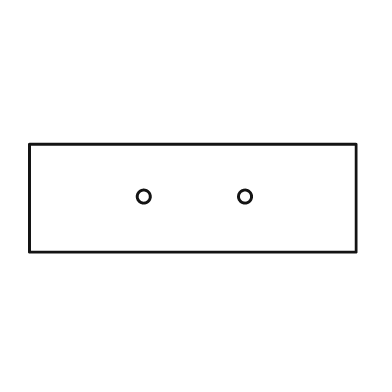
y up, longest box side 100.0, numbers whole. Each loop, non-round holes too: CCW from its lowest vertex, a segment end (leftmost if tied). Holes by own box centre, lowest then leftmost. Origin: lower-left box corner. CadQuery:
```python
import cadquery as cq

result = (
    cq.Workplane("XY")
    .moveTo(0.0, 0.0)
    .lineTo(100.0, 0.0)
    .lineTo(100.0, 33.0)
    .lineTo(0.0, 33.0)
    .close()
    .moveTo(35.0, 17.0)
    .circle(2.0)
    .moveTo(66.0, 17.0)
    .circle(2.0)
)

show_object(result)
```